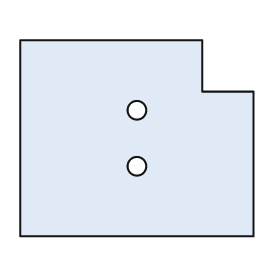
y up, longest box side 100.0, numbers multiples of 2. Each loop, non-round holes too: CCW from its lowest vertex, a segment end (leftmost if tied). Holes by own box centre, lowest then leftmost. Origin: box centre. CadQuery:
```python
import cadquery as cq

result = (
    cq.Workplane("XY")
    .moveTo(-50.0, -42.0)
    .lineTo(50.0, -42.0)
    .lineTo(50.0, 20.0)
    .lineTo(28.0, 20.0)
    .lineTo(28.0, 42.0)
    .lineTo(-50.0, 42.0)
    .close()
    .moveTo(0.0, -12.0)
    .circle(4.0)
    .moveTo(0.0, 12.0)
    .circle(4.0)
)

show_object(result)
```